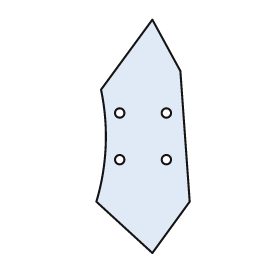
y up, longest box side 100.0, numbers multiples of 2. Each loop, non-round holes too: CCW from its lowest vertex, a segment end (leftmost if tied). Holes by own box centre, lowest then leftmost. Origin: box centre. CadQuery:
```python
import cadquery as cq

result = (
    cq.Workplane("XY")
    .moveTo(4.0, -50.0)
    .lineTo(20.0, -28.0)
    .lineTo(16.0, 28.0)
    .lineTo(4.0, 50.0)
    .lineTo(-18.0, 20.0)
    .threePointArc((-16.0, -4.0), (-20.0, -28.0))
    .close()
    .moveTo(-10.0, -10.0)
    .circle(2.0)
    .moveTo(10.0, -10.0)
    .circle(2.0)
    .moveTo(-10.0, 10.0)
    .circle(2.0)
    .moveTo(10.0, 10.0)
    .circle(2.0)
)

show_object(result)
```